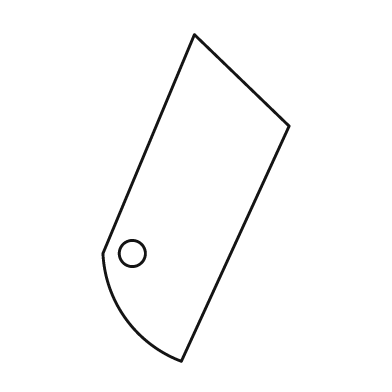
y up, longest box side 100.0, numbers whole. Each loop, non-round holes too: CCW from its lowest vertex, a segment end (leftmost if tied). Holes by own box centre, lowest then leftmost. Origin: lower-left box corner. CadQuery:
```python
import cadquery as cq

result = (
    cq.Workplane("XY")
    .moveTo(24.0, 0.0)
    .lineTo(57.0, 72.0)
    .lineTo(28.0, 100.0)
    .lineTo(0.0, 33.0)
    .threePointArc((7.0, 13.0), (24.0, 0.0))
    .close()
    .moveTo(9.0, 33.0)
    .circle(4.0)
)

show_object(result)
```